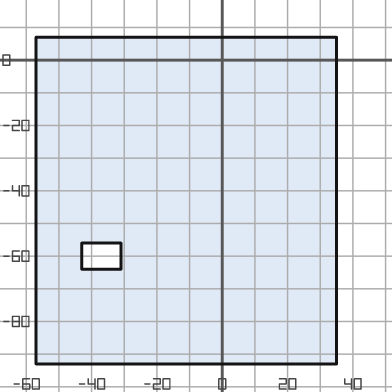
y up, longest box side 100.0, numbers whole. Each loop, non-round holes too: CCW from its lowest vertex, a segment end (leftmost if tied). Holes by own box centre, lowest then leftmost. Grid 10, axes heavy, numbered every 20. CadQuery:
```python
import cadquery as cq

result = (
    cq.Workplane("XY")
    .moveTo(-57.0, -93.0)
    .lineTo(35.0, -93.0)
    .lineTo(35.0, 7.0)
    .lineTo(-57.0, 7.0)
    .close()
    .moveTo(-43.0, -64.0)
    .lineTo(-31.0, -64.0)
    .lineTo(-31.0, -56.0)
    .lineTo(-43.0, -56.0)
    .close()
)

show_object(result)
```